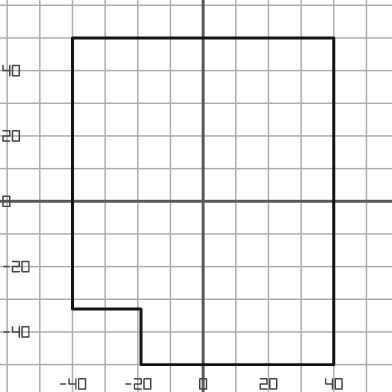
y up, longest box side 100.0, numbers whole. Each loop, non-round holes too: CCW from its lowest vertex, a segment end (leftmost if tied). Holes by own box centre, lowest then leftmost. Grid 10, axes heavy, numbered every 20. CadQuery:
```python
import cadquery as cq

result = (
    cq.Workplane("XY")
    .moveTo(-19.0, -50.0)
    .lineTo(40.0, -50.0)
    .lineTo(40.0, 50.0)
    .lineTo(-40.0, 50.0)
    .lineTo(-40.0, -33.0)
    .lineTo(-19.0, -33.0)
    .close()
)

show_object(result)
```